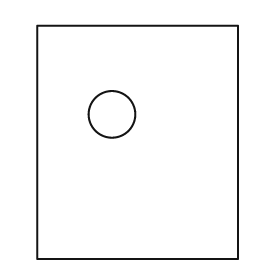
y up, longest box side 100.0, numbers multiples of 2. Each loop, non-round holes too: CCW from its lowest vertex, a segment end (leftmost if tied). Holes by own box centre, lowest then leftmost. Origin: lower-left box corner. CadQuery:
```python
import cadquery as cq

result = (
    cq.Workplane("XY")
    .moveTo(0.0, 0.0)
    .lineTo(86.0, 0.0)
    .lineTo(86.0, 100.0)
    .lineTo(0.0, 100.0)
    .close()
    .moveTo(32.0, 62.0)
    .circle(10.0)
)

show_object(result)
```